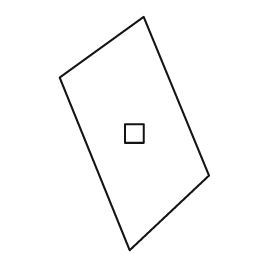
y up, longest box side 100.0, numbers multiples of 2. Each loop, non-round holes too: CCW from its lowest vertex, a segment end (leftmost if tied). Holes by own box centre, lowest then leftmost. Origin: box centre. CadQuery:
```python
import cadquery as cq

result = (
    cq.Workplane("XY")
    .moveTo(-2.0, -50.0)
    .lineTo(32.0, -18.0)
    .lineTo(4.0, 50.0)
    .lineTo(-32.0, 24.0)
    .close()
    .moveTo(-4.0, -4.0)
    .lineTo(4.0, -4.0)
    .lineTo(4.0, 4.0)
    .lineTo(-4.0, 4.0)
    .close()
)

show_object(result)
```